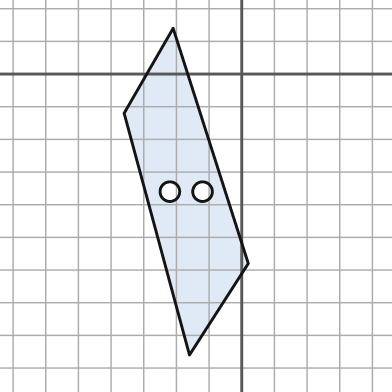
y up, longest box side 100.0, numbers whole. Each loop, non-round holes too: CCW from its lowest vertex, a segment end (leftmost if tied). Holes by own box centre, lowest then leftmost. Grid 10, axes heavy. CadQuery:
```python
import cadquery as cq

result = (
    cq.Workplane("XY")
    .moveTo(-16.0, -86.0)
    .lineTo(2.0, -58.0)
    .lineTo(-21.0, 14.0)
    .lineTo(-36.0, -12.0)
    .close()
    .moveTo(-22.0, -36.0)
    .circle(3.0)
    .moveTo(-12.0, -36.0)
    .circle(3.0)
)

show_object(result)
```